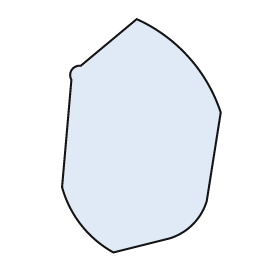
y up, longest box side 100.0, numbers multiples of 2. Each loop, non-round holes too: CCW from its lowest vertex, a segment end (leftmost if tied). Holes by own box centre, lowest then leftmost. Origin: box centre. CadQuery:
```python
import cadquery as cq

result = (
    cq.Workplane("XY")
    .moveTo(-12.0, -50.0)
    .lineTo(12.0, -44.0)
    .threePointArc((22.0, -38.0), (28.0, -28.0))
    .lineTo(34.0, 10.0)
    .threePointArc((20.0, 34.0), (-2.0, 50.0))
    .lineTo(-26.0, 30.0)
    .threePointArc((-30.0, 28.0), (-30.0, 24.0))
    .lineTo(-34.0, -22.0)
    .threePointArc((-26.0, -38.0), (-12.0, -50.0))
    .close()
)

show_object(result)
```